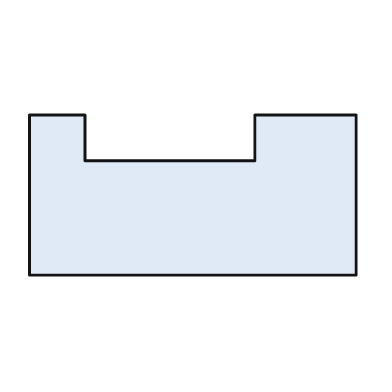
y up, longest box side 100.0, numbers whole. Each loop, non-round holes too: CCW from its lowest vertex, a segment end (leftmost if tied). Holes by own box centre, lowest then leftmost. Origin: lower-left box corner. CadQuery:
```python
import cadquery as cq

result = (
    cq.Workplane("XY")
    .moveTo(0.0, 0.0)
    .lineTo(100.0, 0.0)
    .lineTo(100.0, 49.0)
    .lineTo(69.0, 49.0)
    .lineTo(69.0, 35.0)
    .lineTo(17.0, 35.0)
    .lineTo(17.0, 49.0)
    .lineTo(0.0, 49.0)
    .close()
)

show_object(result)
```